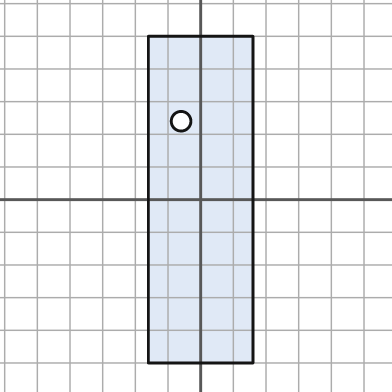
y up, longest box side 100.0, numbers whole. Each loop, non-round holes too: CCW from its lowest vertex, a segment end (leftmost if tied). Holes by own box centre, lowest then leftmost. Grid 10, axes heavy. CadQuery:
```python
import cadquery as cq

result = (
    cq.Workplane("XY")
    .moveTo(-16.0, -50.0)
    .lineTo(16.0, -50.0)
    .lineTo(16.0, 50.0)
    .lineTo(-16.0, 50.0)
    .close()
    .moveTo(-6.0, 24.0)
    .circle(3.0)
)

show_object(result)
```